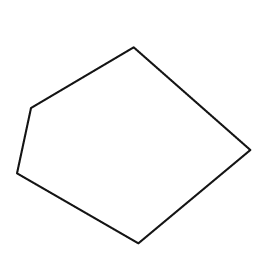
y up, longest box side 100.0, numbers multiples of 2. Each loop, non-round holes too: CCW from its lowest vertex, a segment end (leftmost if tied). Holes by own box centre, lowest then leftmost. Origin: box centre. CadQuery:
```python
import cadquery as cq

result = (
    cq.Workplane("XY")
    .moveTo(2.0, -42.0)
    .lineTo(50.0, -2.0)
    .lineTo(0.0, 42.0)
    .lineTo(-44.0, 16.0)
    .lineTo(-50.0, -12.0)
    .close()
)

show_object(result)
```